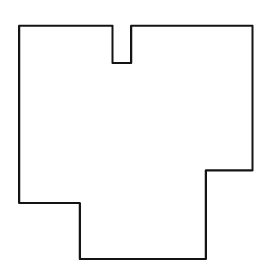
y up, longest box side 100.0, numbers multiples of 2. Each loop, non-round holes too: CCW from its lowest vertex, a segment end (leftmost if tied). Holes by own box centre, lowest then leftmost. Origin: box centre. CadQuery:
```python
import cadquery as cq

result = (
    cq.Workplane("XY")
    .moveTo(-24.0, -50.0)
    .lineTo(30.0, -50.0)
    .lineTo(30.0, -12.0)
    .lineTo(50.0, -12.0)
    .lineTo(50.0, 50.0)
    .lineTo(-2.0, 50.0)
    .lineTo(-2.0, 34.0)
    .lineTo(-10.0, 34.0)
    .lineTo(-10.0, 50.0)
    .lineTo(-50.0, 50.0)
    .lineTo(-50.0, -26.0)
    .lineTo(-24.0, -26.0)
    .close()
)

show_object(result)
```